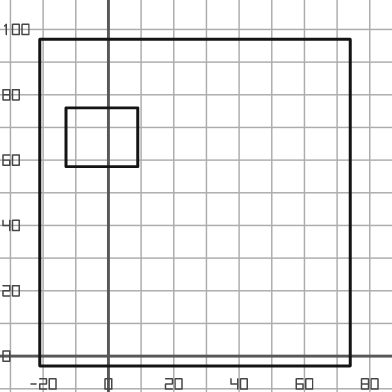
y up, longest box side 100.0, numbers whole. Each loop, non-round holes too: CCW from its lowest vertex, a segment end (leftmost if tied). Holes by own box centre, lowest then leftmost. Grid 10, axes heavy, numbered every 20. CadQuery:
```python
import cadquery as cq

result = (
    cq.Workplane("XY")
    .moveTo(-21.0, -3.0)
    .lineTo(74.0, -3.0)
    .lineTo(74.0, 97.0)
    .lineTo(-21.0, 97.0)
    .close()
    .moveTo(-13.0, 58.0)
    .lineTo(9.0, 58.0)
    .lineTo(9.0, 76.0)
    .lineTo(-13.0, 76.0)
    .close()
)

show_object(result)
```